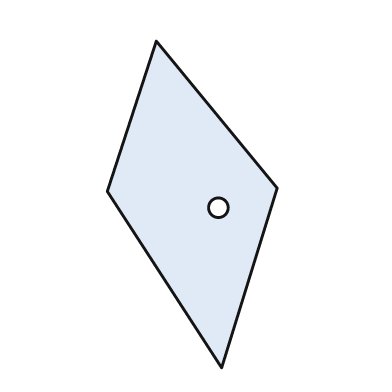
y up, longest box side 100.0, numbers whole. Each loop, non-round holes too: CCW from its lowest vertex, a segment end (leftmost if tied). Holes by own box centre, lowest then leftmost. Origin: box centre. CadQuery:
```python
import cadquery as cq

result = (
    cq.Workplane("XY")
    .moveTo(9.0, -50.0)
    .lineTo(26.0, 5.0)
    .lineTo(-11.0, 50.0)
    .lineTo(-26.0, 4.0)
    .close()
    .moveTo(8.0, -1.0)
    .circle(3.0)
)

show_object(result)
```